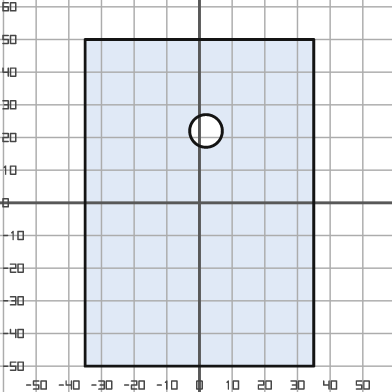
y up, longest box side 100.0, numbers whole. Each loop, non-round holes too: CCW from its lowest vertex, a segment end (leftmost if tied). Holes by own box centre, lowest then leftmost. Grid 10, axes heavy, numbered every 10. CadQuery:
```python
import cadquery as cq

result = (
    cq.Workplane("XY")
    .moveTo(-35.0, -50.0)
    .lineTo(35.0, -50.0)
    .lineTo(35.0, 50.0)
    .lineTo(-35.0, 50.0)
    .close()
    .moveTo(2.0, 22.0)
    .circle(5.0)
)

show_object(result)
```